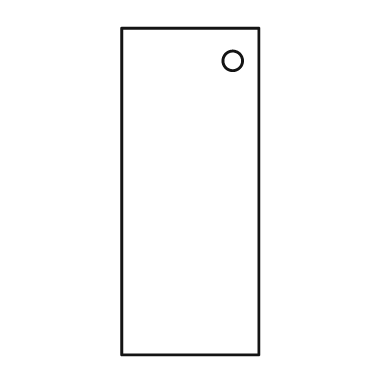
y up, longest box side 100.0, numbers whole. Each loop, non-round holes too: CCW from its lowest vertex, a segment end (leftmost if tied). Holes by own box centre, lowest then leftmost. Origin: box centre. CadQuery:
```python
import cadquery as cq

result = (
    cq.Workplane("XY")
    .moveTo(-21.0, -50.0)
    .lineTo(21.0, -50.0)
    .lineTo(21.0, 50.0)
    .lineTo(-21.0, 50.0)
    .close()
    .moveTo(13.0, 40.0)
    .circle(3.0)
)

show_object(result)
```